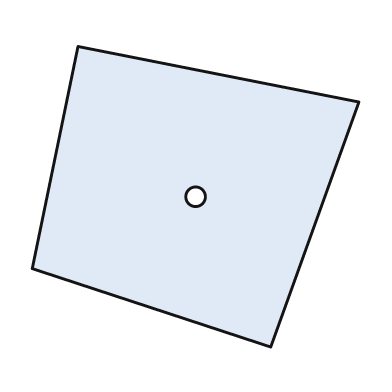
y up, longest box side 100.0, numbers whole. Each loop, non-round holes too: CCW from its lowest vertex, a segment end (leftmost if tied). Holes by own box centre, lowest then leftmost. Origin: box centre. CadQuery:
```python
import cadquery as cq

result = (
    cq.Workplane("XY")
    .moveTo(23.0, -46.0)
    .lineTo(50.0, 29.0)
    .lineTo(-36.0, 46.0)
    .lineTo(-50.0, -22.0)
    .close()
    .moveTo(0.0, 0.0)
    .circle(3.0)
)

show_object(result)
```